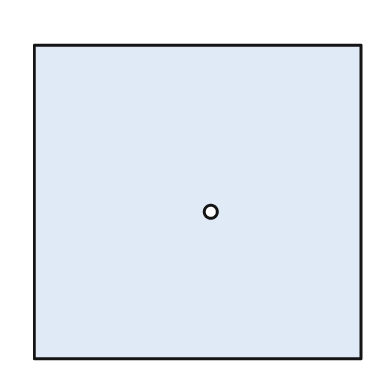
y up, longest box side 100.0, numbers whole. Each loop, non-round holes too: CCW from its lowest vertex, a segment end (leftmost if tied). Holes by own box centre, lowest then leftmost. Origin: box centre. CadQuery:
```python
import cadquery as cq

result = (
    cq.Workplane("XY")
    .moveTo(-50.0, -48.0)
    .lineTo(50.0, -48.0)
    .lineTo(50.0, 48.0)
    .lineTo(-50.0, 48.0)
    .close()
    .moveTo(4.0, -3.0)
    .circle(2.0)
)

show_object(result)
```